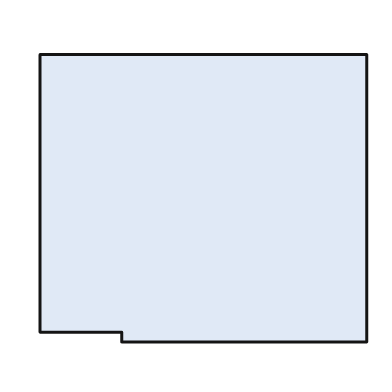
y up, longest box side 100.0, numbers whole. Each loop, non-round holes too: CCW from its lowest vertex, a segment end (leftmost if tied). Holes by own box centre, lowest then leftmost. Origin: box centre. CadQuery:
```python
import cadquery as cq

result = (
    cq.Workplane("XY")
    .moveTo(-25.0, -44.0)
    .lineTo(50.0, -44.0)
    .lineTo(50.0, 44.0)
    .lineTo(-50.0, 44.0)
    .lineTo(-50.0, -41.0)
    .lineTo(-25.0, -41.0)
    .close()
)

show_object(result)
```